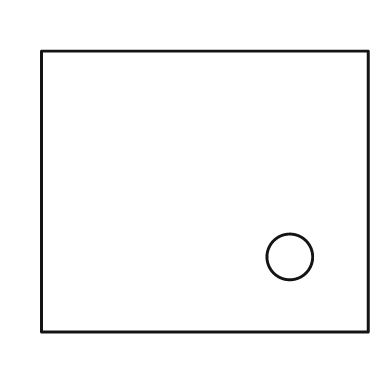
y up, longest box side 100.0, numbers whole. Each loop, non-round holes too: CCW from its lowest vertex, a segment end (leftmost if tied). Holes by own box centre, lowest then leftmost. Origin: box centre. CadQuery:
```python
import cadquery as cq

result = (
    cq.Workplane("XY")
    .moveTo(-50.0, -43.0)
    .lineTo(50.0, -43.0)
    .lineTo(50.0, 43.0)
    .lineTo(-50.0, 43.0)
    .close()
    .moveTo(26.0, -20.0)
    .circle(7.0)
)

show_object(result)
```